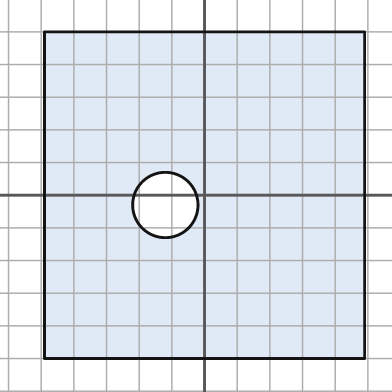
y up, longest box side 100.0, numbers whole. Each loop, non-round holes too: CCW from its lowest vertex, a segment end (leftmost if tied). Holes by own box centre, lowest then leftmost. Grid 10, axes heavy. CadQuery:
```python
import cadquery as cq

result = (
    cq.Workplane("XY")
    .moveTo(-49.0, -50.0)
    .lineTo(49.0, -50.0)
    .lineTo(49.0, 50.0)
    .lineTo(-49.0, 50.0)
    .close()
    .moveTo(-12.0, -3.0)
    .circle(10.0)
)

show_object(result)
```